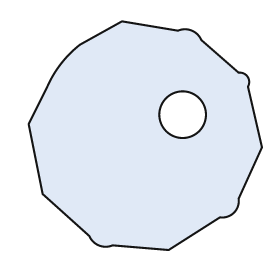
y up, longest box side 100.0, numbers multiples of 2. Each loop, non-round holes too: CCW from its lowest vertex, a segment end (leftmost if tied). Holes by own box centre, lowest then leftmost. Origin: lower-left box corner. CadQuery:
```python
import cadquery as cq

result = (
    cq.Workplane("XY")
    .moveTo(60.0, 0.0)
    .lineTo(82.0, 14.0)
    .threePointArc((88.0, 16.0), (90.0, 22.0))
    .lineTo(100.0, 44.0)
    .lineTo(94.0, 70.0)
    .threePointArc((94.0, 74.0), (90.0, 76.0))
    .lineTo(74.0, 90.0)
    .threePointArc((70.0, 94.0), (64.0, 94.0))
    .lineTo(40.0, 98.0)
    .lineTo(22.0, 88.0)
    .threePointArc((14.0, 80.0), (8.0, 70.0))
    .lineTo(0.0, 54.0)
    .lineTo(6.0, 24.0)
    .lineTo(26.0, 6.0)
    .threePointArc((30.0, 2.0), (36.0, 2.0))
    .close()
    .moveTo(66.0, 58.0)
    .circle(10.0)
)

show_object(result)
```